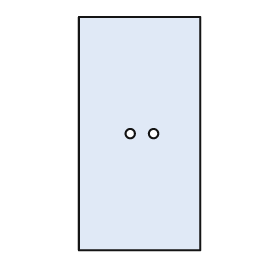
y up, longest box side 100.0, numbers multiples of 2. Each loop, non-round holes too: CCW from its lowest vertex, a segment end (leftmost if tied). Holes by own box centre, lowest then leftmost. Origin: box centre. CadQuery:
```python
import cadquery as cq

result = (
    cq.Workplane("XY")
    .moveTo(-26.0, -50.0)
    .lineTo(26.0, -50.0)
    .lineTo(26.0, 50.0)
    .lineTo(-26.0, 50.0)
    .close()
    .moveTo(-4.0, 0.0)
    .circle(2.0)
    .moveTo(6.0, 0.0)
    .circle(2.0)
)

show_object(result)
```